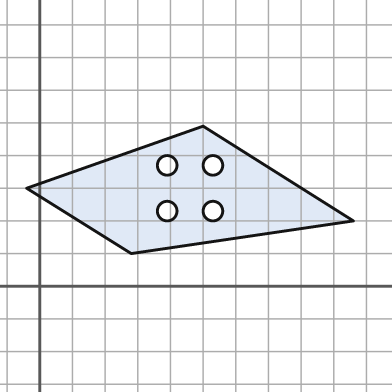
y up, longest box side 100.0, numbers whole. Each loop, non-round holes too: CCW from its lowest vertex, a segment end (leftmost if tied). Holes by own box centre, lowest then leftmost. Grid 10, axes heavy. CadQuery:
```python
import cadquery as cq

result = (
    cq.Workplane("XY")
    .moveTo(28.0, 10.0)
    .lineTo(96.0, 20.0)
    .lineTo(50.0, 49.0)
    .lineTo(-4.0, 30.0)
    .close()
    .moveTo(39.0, 23.0)
    .circle(3.0)
    .moveTo(53.0, 23.0)
    .circle(3.0)
    .moveTo(39.0, 37.0)
    .circle(3.0)
    .moveTo(53.0, 37.0)
    .circle(3.0)
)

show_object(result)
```